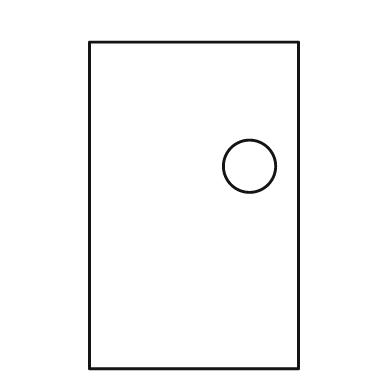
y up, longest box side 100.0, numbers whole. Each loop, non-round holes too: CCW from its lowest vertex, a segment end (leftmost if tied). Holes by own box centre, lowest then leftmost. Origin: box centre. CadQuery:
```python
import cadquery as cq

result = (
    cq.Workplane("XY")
    .moveTo(-32.0, -50.0)
    .lineTo(32.0, -50.0)
    .lineTo(32.0, 50.0)
    .lineTo(-32.0, 50.0)
    .close()
    .moveTo(17.0, 12.0)
    .circle(8.0)
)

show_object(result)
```